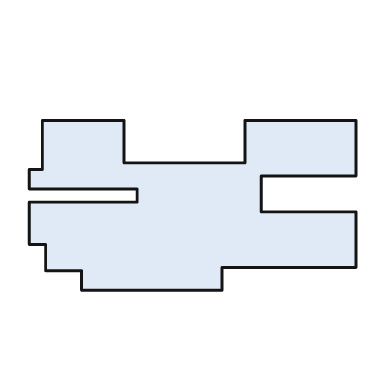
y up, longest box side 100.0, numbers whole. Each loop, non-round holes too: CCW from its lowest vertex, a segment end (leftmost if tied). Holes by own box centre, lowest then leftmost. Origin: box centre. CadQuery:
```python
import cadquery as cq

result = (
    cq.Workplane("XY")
    .moveTo(-34.0, -26.0)
    .lineTo(9.0, -26.0)
    .lineTo(9.0, -19.0)
    .lineTo(50.0, -19.0)
    .lineTo(50.0, -2.0)
    .lineTo(21.0, -2.0)
    .lineTo(21.0, 9.0)
    .lineTo(50.0, 9.0)
    .lineTo(50.0, 26.0)
    .lineTo(16.0, 26.0)
    .lineTo(16.0, 13.0)
    .lineTo(-21.0, 13.0)
    .lineTo(-21.0, 26.0)
    .lineTo(-46.0, 26.0)
    .lineTo(-46.0, 11.0)
    .lineTo(-50.0, 11.0)
    .lineTo(-50.0, 5.0)
    .lineTo(-17.0, 5.0)
    .lineTo(-17.0, 1.0)
    .lineTo(-50.0, 1.0)
    .lineTo(-50.0, -12.0)
    .lineTo(-45.0, -12.0)
    .lineTo(-45.0, -20.0)
    .lineTo(-34.0, -20.0)
    .close()
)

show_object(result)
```